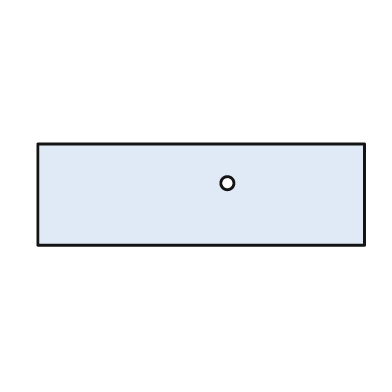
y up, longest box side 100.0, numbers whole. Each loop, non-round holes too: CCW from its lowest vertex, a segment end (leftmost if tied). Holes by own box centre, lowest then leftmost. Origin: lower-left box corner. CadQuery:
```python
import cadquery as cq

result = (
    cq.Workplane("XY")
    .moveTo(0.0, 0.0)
    .lineTo(100.0, 0.0)
    .lineTo(100.0, 31.0)
    .lineTo(0.0, 31.0)
    .close()
    .moveTo(58.0, 19.0)
    .circle(2.0)
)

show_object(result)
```